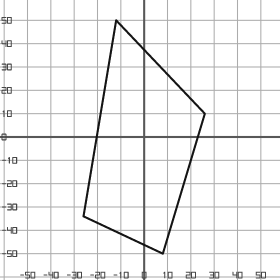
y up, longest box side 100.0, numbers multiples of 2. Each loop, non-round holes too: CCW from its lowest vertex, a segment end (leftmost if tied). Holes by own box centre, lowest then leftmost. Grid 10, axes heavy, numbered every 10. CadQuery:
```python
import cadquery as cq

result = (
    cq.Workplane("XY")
    .moveTo(8.0, -50.0)
    .lineTo(26.0, 10.0)
    .lineTo(-12.0, 50.0)
    .lineTo(-26.0, -34.0)
    .close()
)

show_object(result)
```